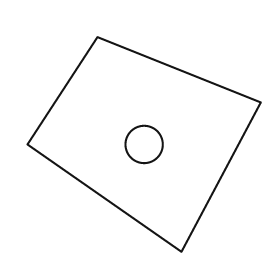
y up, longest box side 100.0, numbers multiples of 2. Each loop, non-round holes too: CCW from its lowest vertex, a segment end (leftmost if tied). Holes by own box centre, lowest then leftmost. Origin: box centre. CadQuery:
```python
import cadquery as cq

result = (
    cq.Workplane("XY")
    .moveTo(16.0, -46.0)
    .lineTo(50.0, 18.0)
    .lineTo(-20.0, 46.0)
    .lineTo(-50.0, 0.0)
    .close()
    .moveTo(0.0, 0.0)
    .circle(8.0)
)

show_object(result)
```